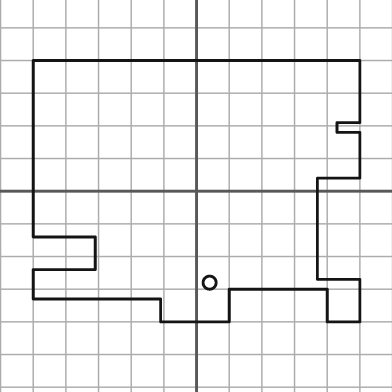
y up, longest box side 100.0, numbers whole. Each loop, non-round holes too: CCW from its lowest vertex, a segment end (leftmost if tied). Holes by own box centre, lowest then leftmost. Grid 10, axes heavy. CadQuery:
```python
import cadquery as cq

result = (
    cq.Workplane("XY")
    .moveTo(-11.0, -40.0)
    .lineTo(10.0, -40.0)
    .lineTo(10.0, -30.0)
    .lineTo(40.0, -30.0)
    .lineTo(40.0, -40.0)
    .lineTo(50.0, -40.0)
    .lineTo(50.0, -27.0)
    .lineTo(37.0, -27.0)
    .lineTo(37.0, 4.0)
    .lineTo(50.0, 4.0)
    .lineTo(50.0, 18.0)
    .lineTo(43.0, 18.0)
    .lineTo(43.0, 21.0)
    .lineTo(50.0, 21.0)
    .lineTo(50.0, 40.0)
    .lineTo(-50.0, 40.0)
    .lineTo(-50.0, -14.0)
    .lineTo(-31.0, -14.0)
    .lineTo(-31.0, -24.0)
    .lineTo(-50.0, -24.0)
    .lineTo(-50.0, -33.0)
    .lineTo(-11.0, -33.0)
    .close()
    .moveTo(4.0, -28.0)
    .circle(2.0)
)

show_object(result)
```